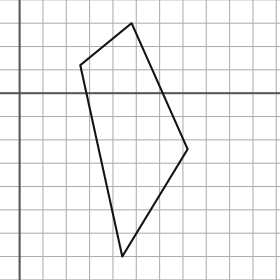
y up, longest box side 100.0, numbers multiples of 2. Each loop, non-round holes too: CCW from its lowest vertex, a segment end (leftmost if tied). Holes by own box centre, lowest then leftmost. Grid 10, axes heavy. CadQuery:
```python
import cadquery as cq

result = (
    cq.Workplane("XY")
    .moveTo(44.0, -70.0)
    .lineTo(72.0, -24.0)
    .lineTo(48.0, 30.0)
    .lineTo(26.0, 12.0)
    .close()
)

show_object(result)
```